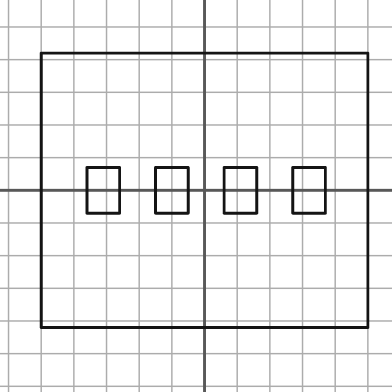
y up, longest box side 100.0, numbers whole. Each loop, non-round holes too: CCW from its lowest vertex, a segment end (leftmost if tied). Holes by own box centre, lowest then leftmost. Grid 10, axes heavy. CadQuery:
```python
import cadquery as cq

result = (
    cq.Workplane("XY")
    .moveTo(-50.0, -42.0)
    .lineTo(50.0, -42.0)
    .lineTo(50.0, 42.0)
    .lineTo(-50.0, 42.0)
    .close()
    .moveTo(-36.0, -7.0)
    .lineTo(-26.0, -7.0)
    .lineTo(-26.0, 7.0)
    .lineTo(-36.0, 7.0)
    .close()
    .moveTo(-15.0, -7.0)
    .lineTo(-5.0, -7.0)
    .lineTo(-5.0, 7.0)
    .lineTo(-15.0, 7.0)
    .close()
    .moveTo(6.0, -7.0)
    .lineTo(16.0, -7.0)
    .lineTo(16.0, 7.0)
    .lineTo(6.0, 7.0)
    .close()
    .moveTo(27.0, -7.0)
    .lineTo(37.0, -7.0)
    .lineTo(37.0, 7.0)
    .lineTo(27.0, 7.0)
    .close()
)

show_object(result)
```